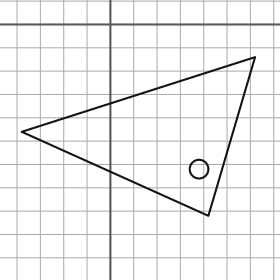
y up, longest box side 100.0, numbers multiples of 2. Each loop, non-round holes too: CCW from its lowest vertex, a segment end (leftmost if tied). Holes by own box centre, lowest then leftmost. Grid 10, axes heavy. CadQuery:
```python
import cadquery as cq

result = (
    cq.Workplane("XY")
    .moveTo(42.0, -82.0)
    .lineTo(62.0, -14.0)
    .lineTo(-38.0, -46.0)
    .close()
    .moveTo(38.0, -62.0)
    .circle(4.0)
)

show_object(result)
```